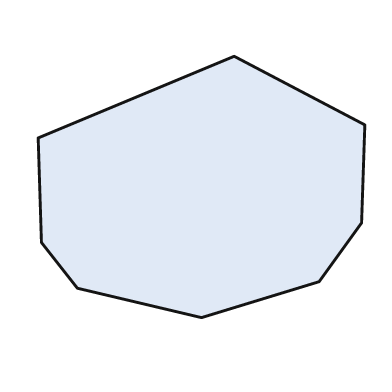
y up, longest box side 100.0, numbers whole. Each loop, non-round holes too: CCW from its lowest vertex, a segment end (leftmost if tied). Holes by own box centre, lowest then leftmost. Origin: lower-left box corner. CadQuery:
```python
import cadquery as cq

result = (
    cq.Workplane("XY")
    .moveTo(50.0, 0.0)
    .lineTo(86.0, 11.0)
    .lineTo(99.0, 29.0)
    .lineTo(100.0, 59.0)
    .lineTo(60.0, 80.0)
    .lineTo(0.0, 55.0)
    .lineTo(1.0, 23.0)
    .lineTo(12.0, 9.0)
    .close()
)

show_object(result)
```